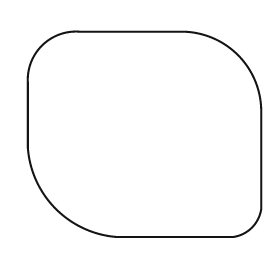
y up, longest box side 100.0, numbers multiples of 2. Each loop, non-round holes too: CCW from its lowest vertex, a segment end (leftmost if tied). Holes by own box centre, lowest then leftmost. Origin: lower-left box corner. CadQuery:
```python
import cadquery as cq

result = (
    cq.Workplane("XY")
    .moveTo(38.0, 0.0)
    .lineTo(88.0, 0.0)
    .threePointArc((96.0, 4.0), (100.0, 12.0))
    .lineTo(100.0, 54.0)
    .threePointArc((90.0, 78.0), (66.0, 88.0))
    .lineTo(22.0, 88.0)
    .threePointArc((6.0, 82.0), (0.0, 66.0))
    .lineTo(0.0, 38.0)
    .threePointArc((12.0, 12.0), (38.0, 0.0))
    .close()
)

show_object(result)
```